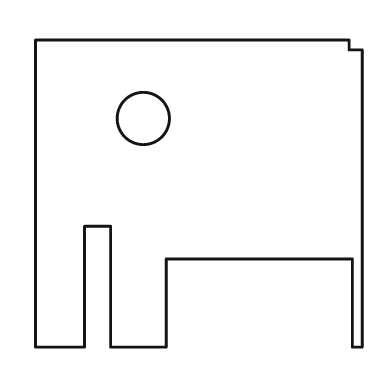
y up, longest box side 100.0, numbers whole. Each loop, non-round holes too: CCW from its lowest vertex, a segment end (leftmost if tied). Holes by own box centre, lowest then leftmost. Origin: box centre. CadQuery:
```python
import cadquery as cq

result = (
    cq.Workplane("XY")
    .moveTo(-50.0, -47.0)
    .lineTo(-35.0, -47.0)
    .lineTo(-35.0, -10.0)
    .lineTo(-27.0, -10.0)
    .lineTo(-27.0, -47.0)
    .lineTo(-10.0, -47.0)
    .lineTo(-10.0, -20.0)
    .lineTo(47.0, -20.0)
    .lineTo(47.0, -47.0)
    .lineTo(50.0, -47.0)
    .lineTo(50.0, 44.0)
    .lineTo(46.0, 44.0)
    .lineTo(46.0, 47.0)
    .lineTo(-50.0, 47.0)
    .close()
    .moveTo(-17.0, 23.0)
    .circle(8.0)
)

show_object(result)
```